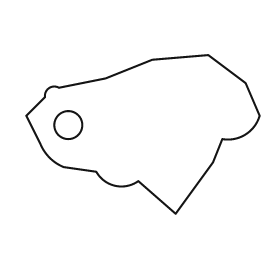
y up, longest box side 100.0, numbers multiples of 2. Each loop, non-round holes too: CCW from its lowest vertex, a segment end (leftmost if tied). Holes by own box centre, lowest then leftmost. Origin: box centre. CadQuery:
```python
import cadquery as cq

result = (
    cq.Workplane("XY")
    .moveTo(14.0, -34.0)
    .lineTo(30.0, -12.0)
    .lineTo(34.0, -2.0)
    .threePointArc((44.0, 0.0), (50.0, 8.0))
    .lineTo(44.0, 22.0)
    .lineTo(28.0, 34.0)
    .lineTo(4.0, 32.0)
    .lineTo(-16.0, 24.0)
    .lineTo(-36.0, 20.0)
    .threePointArc((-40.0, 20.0), (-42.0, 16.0))
    .lineTo(-50.0, 8.0)
    .lineTo(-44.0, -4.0)
    .threePointArc((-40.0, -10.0), (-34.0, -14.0))
    .lineTo(-20.0, -16.0)
    .threePointArc((-12.0, -22.0), (-2.0, -20.0))
    .close()
    .moveTo(-32.0, 4.0)
    .circle(6.0)
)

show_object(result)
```